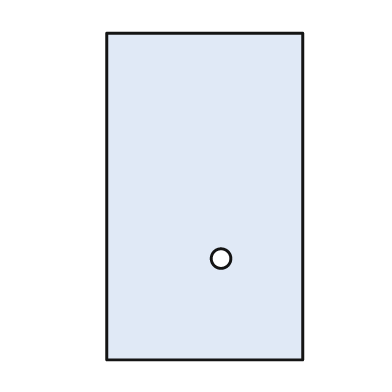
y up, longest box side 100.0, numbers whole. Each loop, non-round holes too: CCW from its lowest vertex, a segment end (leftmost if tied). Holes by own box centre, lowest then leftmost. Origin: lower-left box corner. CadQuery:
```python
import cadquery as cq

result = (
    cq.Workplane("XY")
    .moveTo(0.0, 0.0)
    .lineTo(60.0, 0.0)
    .lineTo(60.0, 100.0)
    .lineTo(0.0, 100.0)
    .close()
    .moveTo(35.0, 31.0)
    .circle(3.0)
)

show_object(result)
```